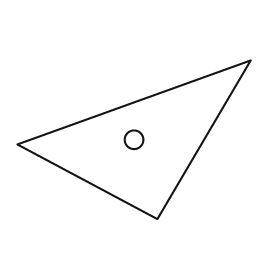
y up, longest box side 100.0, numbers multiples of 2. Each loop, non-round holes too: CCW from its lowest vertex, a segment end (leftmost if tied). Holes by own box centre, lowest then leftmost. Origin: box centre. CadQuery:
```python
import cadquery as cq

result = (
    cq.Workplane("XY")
    .moveTo(10.0, -34.0)
    .lineTo(50.0, 34.0)
    .lineTo(-50.0, -2.0)
    .close()
    .moveTo(0.0, 0.0)
    .circle(4.0)
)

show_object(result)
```